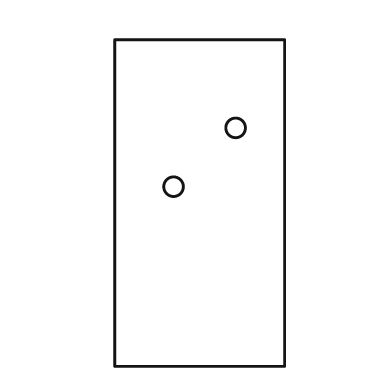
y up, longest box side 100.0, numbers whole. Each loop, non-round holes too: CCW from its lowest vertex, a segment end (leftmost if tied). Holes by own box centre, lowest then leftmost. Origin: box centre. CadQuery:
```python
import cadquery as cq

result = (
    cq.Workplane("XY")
    .moveTo(-26.0, -50.0)
    .lineTo(26.0, -50.0)
    .lineTo(26.0, 50.0)
    .lineTo(-26.0, 50.0)
    .close()
    .moveTo(-8.0, 5.0)
    .circle(3.0)
    .moveTo(11.0, 23.0)
    .circle(3.0)
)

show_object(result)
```